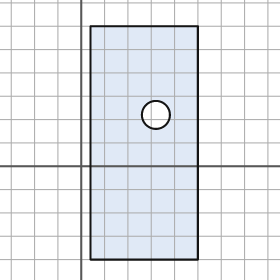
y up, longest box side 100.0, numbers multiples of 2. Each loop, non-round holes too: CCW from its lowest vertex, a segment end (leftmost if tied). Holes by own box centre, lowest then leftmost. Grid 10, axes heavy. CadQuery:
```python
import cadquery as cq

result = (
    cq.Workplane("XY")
    .moveTo(4.0, -40.0)
    .lineTo(50.0, -40.0)
    .lineTo(50.0, 60.0)
    .lineTo(4.0, 60.0)
    .close()
    .moveTo(32.0, 22.0)
    .circle(6.0)
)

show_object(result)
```